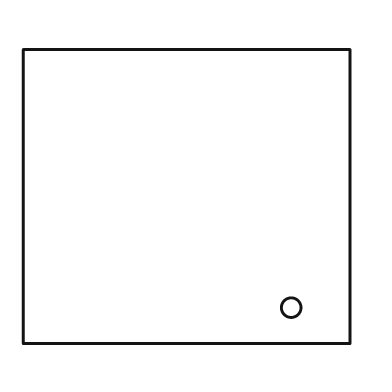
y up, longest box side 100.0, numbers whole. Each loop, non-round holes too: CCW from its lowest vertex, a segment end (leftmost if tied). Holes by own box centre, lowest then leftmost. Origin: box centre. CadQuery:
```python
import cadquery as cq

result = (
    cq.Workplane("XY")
    .moveTo(-50.0, -45.0)
    .lineTo(50.0, -45.0)
    .lineTo(50.0, 45.0)
    .lineTo(-50.0, 45.0)
    .close()
    .moveTo(32.0, -34.0)
    .circle(3.0)
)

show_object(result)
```